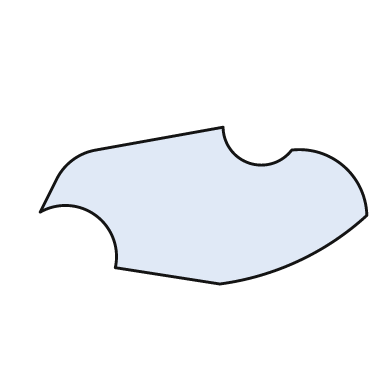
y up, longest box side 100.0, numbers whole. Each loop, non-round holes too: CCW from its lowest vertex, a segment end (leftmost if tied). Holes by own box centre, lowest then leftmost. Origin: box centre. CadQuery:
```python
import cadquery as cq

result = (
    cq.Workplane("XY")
    .moveTo(5.0, -24.0)
    .threePointArc((29.0, -17.0), (50.0, -3.0))
    .threePointArc((43.0, 12.0), (27.0, 17.0))
    .threePointArc((14.0, 13.0), (6.0, 24.0))
    .lineTo(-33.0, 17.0)
    .threePointArc((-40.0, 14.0), (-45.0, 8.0))
    .lineTo(-50.0, -2.0)
    .threePointArc((-33.0, -3.0), (-27.0, -19.0))
    .close()
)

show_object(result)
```